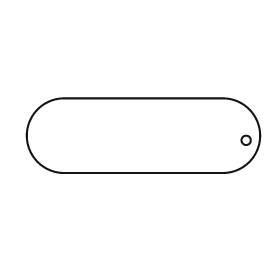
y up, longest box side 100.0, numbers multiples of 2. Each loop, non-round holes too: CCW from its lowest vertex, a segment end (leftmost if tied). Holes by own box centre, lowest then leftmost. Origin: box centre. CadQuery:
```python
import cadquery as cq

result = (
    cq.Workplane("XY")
    .moveTo(-34.0, -16.0)
    .lineTo(34.0, -16.0)
    .threePointArc((50.0, 0.0), (34.0, 16.0))
    .lineTo(-34.0, 16.0)
    .threePointArc((-50.0, 0.0), (-34.0, -16.0))
    .close()
    .moveTo(44.0, -2.0)
    .circle(2.0)
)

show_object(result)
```